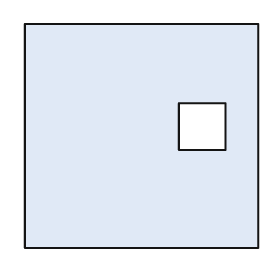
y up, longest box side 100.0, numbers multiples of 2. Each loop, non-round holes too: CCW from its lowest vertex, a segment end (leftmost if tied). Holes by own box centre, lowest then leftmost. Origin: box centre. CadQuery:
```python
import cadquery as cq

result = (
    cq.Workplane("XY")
    .moveTo(-50.0, -48.0)
    .lineTo(50.0, -48.0)
    .lineTo(50.0, 48.0)
    .lineTo(-50.0, 48.0)
    .close()
    .moveTo(16.0, -6.0)
    .lineTo(36.0, -6.0)
    .lineTo(36.0, 14.0)
    .lineTo(16.0, 14.0)
    .close()
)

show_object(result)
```